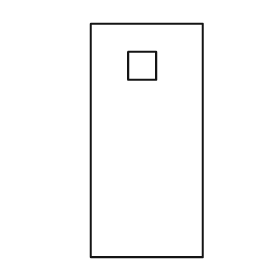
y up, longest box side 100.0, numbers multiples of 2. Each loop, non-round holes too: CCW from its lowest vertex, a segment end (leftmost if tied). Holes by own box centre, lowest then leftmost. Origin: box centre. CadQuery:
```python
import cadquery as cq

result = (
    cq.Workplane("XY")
    .moveTo(-24.0, -50.0)
    .lineTo(24.0, -50.0)
    .lineTo(24.0, 50.0)
    .lineTo(-24.0, 50.0)
    .close()
    .moveTo(-8.0, 26.0)
    .lineTo(4.0, 26.0)
    .lineTo(4.0, 38.0)
    .lineTo(-8.0, 38.0)
    .close()
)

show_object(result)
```